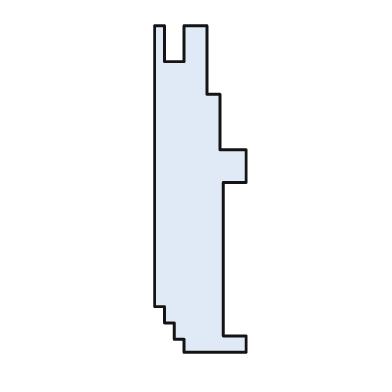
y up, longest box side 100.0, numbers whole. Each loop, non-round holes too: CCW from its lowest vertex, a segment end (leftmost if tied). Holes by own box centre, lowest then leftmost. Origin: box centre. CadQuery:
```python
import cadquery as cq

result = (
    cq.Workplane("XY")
    .moveTo(-5.0, -50.0)
    .lineTo(14.0, -50.0)
    .lineTo(14.0, -45.0)
    .lineTo(7.0, -45.0)
    .lineTo(7.0, 2.0)
    .lineTo(14.0, 2.0)
    .lineTo(14.0, 12.0)
    .lineTo(6.0, 12.0)
    .lineTo(6.0, 29.0)
    .lineTo(2.0, 29.0)
    .lineTo(2.0, 50.0)
    .lineTo(-5.0, 50.0)
    .lineTo(-5.0, 39.0)
    .lineTo(-11.0, 39.0)
    .lineTo(-11.0, 50.0)
    .lineTo(-14.0, 50.0)
    .lineTo(-14.0, -36.0)
    .lineTo(-11.0, -36.0)
    .lineTo(-11.0, -41.0)
    .lineTo(-8.0, -41.0)
    .lineTo(-8.0, -46.0)
    .lineTo(-5.0, -46.0)
    .close()
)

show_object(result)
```